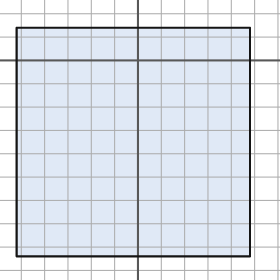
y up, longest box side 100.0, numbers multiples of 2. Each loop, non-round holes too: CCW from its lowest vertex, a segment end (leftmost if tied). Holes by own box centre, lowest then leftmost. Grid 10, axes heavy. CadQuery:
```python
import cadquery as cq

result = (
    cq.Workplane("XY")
    .moveTo(-52.0, -84.0)
    .lineTo(48.0, -84.0)
    .lineTo(48.0, 14.0)
    .lineTo(-52.0, 14.0)
    .close()
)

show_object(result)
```